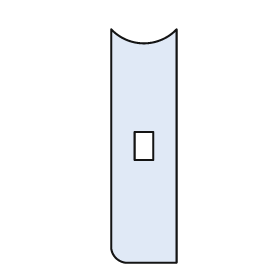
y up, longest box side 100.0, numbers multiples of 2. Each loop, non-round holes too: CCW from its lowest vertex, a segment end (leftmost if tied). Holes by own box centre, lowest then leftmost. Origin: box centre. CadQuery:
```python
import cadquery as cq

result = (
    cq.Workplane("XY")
    .moveTo(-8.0, -50.0)
    .lineTo(14.0, -50.0)
    .lineTo(14.0, 50.0)
    .threePointArc((0.0, 44.0), (-14.0, 50.0))
    .lineTo(-14.0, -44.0)
    .threePointArc((-12.0, -48.0), (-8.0, -50.0))
    .close()
    .moveTo(-4.0, -6.0)
    .lineTo(4.0, -6.0)
    .lineTo(4.0, 6.0)
    .lineTo(-4.0, 6.0)
    .close()
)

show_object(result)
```